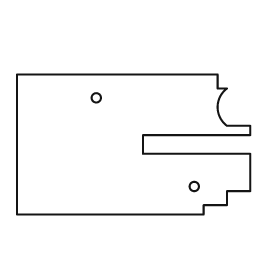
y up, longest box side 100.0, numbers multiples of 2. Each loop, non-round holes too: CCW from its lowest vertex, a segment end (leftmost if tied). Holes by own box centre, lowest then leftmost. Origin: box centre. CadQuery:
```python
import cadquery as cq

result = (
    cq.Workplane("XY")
    .moveTo(-50.0, -30.0)
    .lineTo(30.0, -30.0)
    .lineTo(30.0, -26.0)
    .lineTo(40.0, -26.0)
    .lineTo(40.0, -20.0)
    .lineTo(50.0, -20.0)
    .lineTo(50.0, -4.0)
    .lineTo(4.0, -4.0)
    .lineTo(4.0, 4.0)
    .lineTo(50.0, 4.0)
    .lineTo(50.0, 8.0)
    .lineTo(40.0, 8.0)
    .threePointArc((36.0, 16.0), (40.0, 24.0))
    .lineTo(36.0, 24.0)
    .lineTo(36.0, 30.0)
    .lineTo(-50.0, 30.0)
    .close()
    .moveTo(26.0, -18.0)
    .circle(2.0)
    .moveTo(-16.0, 20.0)
    .circle(2.0)
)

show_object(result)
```